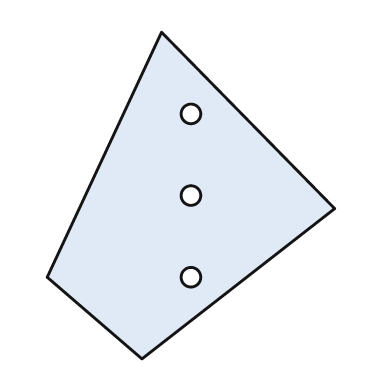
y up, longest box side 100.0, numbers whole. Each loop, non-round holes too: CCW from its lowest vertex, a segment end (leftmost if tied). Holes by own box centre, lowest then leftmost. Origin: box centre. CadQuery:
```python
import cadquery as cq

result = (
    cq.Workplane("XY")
    .moveTo(-15.0, -50.0)
    .lineTo(44.0, -4.0)
    .lineTo(-9.0, 50.0)
    .lineTo(-44.0, -25.0)
    .close()
    .moveTo(0.0, -25.0)
    .circle(3.0)
    .moveTo(0.0, 0.0)
    .circle(3.0)
    .moveTo(0.0, 25.0)
    .circle(3.0)
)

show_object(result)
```